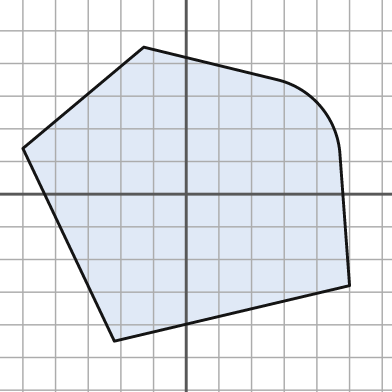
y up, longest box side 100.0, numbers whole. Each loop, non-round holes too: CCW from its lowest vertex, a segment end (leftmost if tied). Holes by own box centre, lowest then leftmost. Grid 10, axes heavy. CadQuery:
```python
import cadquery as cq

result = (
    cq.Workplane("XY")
    .moveTo(-22.0, -45.0)
    .lineTo(50.0, -28.0)
    .lineTo(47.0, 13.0)
    .threePointArc((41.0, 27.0), (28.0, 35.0))
    .lineTo(-13.0, 45.0)
    .lineTo(-50.0, 14.0)
    .close()
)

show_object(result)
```